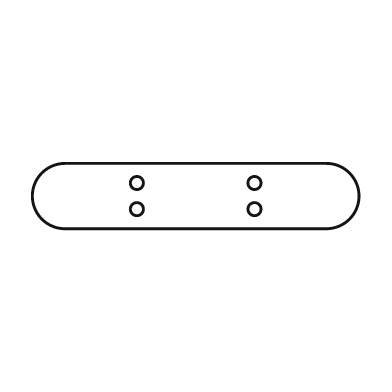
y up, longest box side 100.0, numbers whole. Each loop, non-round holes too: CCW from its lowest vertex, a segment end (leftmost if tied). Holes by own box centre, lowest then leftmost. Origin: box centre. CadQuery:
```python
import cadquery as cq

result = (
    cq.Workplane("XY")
    .moveTo(-40.0, -10.0)
    .lineTo(40.0, -10.0)
    .threePointArc((50.0, 0.0), (40.0, 10.0))
    .lineTo(-40.0, 10.0)
    .threePointArc((-50.0, 0.0), (-40.0, -10.0))
    .close()
    .moveTo(-18.0, -4.0)
    .circle(2.0)
    .moveTo(18.0, -4.0)
    .circle(2.0)
    .moveTo(-18.0, 4.0)
    .circle(2.0)
    .moveTo(18.0, 4.0)
    .circle(2.0)
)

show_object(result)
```